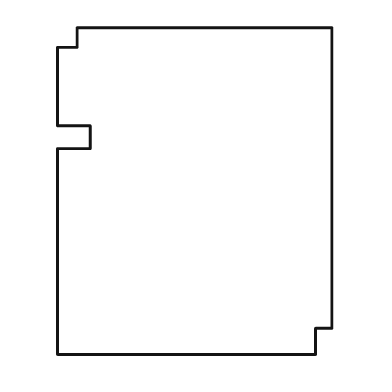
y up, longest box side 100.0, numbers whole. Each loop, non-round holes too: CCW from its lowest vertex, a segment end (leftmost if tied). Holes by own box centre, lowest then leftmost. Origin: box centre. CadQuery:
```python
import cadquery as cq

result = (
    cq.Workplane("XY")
    .moveTo(-42.0, -50.0)
    .lineTo(37.0, -50.0)
    .lineTo(37.0, -42.0)
    .lineTo(42.0, -42.0)
    .lineTo(42.0, 50.0)
    .lineTo(-36.0, 50.0)
    .lineTo(-36.0, 44.0)
    .lineTo(-42.0, 44.0)
    .lineTo(-42.0, 20.0)
    .lineTo(-32.0, 20.0)
    .lineTo(-32.0, 13.0)
    .lineTo(-42.0, 13.0)
    .close()
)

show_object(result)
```